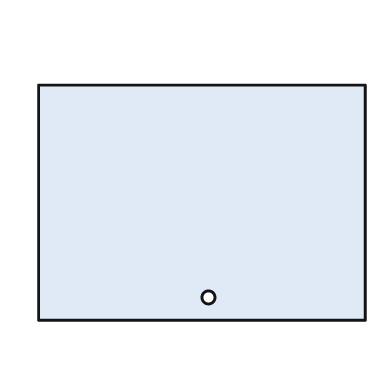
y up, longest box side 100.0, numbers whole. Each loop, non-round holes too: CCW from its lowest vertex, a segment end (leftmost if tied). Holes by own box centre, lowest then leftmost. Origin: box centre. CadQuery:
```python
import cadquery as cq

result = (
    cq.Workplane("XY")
    .moveTo(-50.0, -36.0)
    .lineTo(50.0, -36.0)
    .lineTo(50.0, 36.0)
    .lineTo(-50.0, 36.0)
    .close()
    .moveTo(2.0, -29.0)
    .circle(2.0)
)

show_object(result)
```